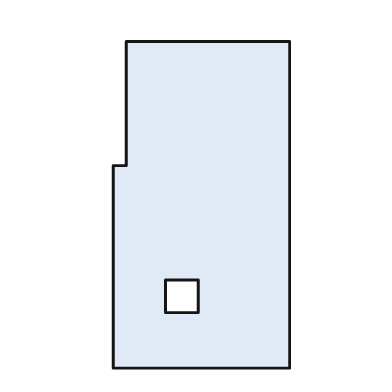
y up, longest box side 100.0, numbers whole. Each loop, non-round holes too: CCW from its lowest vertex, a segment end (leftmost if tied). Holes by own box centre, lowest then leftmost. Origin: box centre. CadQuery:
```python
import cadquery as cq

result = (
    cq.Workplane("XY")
    .moveTo(-27.0, -50.0)
    .lineTo(27.0, -50.0)
    .lineTo(27.0, 50.0)
    .lineTo(-23.0, 50.0)
    .lineTo(-23.0, 12.0)
    .lineTo(-27.0, 12.0)
    .close()
    .moveTo(-11.0, -33.0)
    .lineTo(-1.0, -33.0)
    .lineTo(-1.0, -23.0)
    .lineTo(-11.0, -23.0)
    .close()
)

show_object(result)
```